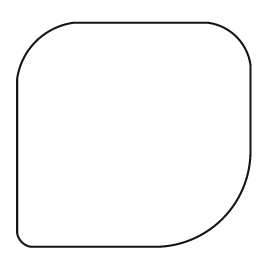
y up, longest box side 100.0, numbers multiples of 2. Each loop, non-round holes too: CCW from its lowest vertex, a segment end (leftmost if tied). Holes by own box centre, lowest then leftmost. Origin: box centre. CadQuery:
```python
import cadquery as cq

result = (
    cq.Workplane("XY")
    .moveTo(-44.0, -48.0)
    .lineTo(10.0, -48.0)
    .threePointArc((38.0, -36.0), (50.0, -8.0))
    .lineTo(50.0, 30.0)
    .threePointArc((44.0, 42.0), (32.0, 48.0))
    .lineTo(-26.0, 48.0)
    .threePointArc((-42.0, 40.0), (-50.0, 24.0))
    .lineTo(-50.0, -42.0)
    .threePointArc((-48.0, -46.0), (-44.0, -48.0))
    .close()
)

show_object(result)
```